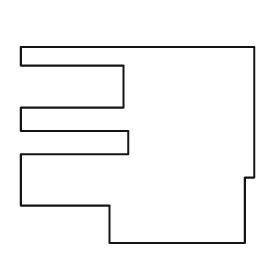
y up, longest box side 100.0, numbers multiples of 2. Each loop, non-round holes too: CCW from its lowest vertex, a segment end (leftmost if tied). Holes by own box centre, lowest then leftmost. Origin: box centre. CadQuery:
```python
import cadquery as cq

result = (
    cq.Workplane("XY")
    .moveTo(-12.0, -42.0)
    .lineTo(46.0, -42.0)
    .lineTo(46.0, -14.0)
    .lineTo(50.0, -14.0)
    .lineTo(50.0, 42.0)
    .lineTo(-50.0, 42.0)
    .lineTo(-50.0, 34.0)
    .lineTo(-6.0, 34.0)
    .lineTo(-6.0, 16.0)
    .lineTo(-50.0, 16.0)
    .lineTo(-50.0, 6.0)
    .lineTo(-4.0, 6.0)
    .lineTo(-4.0, -4.0)
    .lineTo(-50.0, -4.0)
    .lineTo(-50.0, -26.0)
    .lineTo(-12.0, -26.0)
    .close()
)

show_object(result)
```